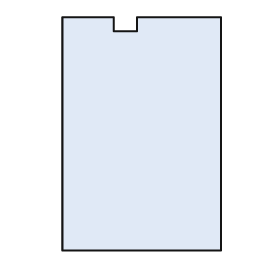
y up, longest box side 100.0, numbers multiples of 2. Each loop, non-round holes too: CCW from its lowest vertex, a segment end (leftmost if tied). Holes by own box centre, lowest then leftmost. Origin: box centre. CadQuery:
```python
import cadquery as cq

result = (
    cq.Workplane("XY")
    .moveTo(-34.0, -50.0)
    .lineTo(34.0, -50.0)
    .lineTo(34.0, 50.0)
    .lineTo(-2.0, 50.0)
    .lineTo(-2.0, 44.0)
    .lineTo(-12.0, 44.0)
    .lineTo(-12.0, 50.0)
    .lineTo(-34.0, 50.0)
    .close()
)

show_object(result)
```